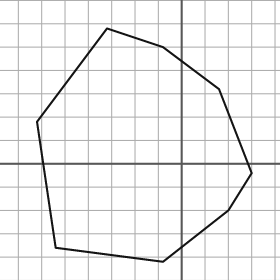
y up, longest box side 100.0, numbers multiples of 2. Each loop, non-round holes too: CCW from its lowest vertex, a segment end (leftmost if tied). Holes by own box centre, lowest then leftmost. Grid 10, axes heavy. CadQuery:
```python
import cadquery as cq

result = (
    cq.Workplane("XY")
    .moveTo(-8.0, -42.0)
    .lineTo(20.0, -20.0)
    .lineTo(30.0, -4.0)
    .lineTo(16.0, 32.0)
    .lineTo(-8.0, 50.0)
    .lineTo(-32.0, 58.0)
    .lineTo(-62.0, 18.0)
    .lineTo(-54.0, -36.0)
    .close()
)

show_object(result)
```